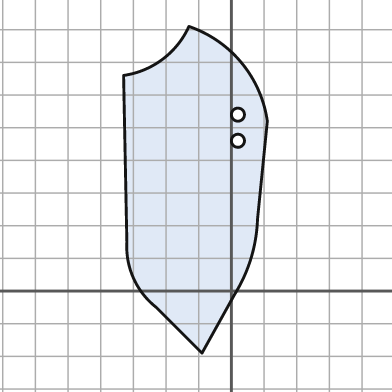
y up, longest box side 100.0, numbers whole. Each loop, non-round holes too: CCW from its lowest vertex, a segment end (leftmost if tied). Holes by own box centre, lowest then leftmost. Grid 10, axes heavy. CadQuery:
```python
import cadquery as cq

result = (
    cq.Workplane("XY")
    .moveTo(-9.0, -19.0)
    .lineTo(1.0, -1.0)
    .threePointArc((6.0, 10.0), (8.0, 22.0))
    .lineTo(11.0, 52.0)
    .threePointArc((3.0, 70.0), (-13.0, 81.0))
    .threePointArc((-21.0, 71.0), (-33.0, 66.0))
    .lineTo(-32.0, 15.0)
    .threePointArc((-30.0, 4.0), (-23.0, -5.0))
    .close()
    .moveTo(2.0, 46.0)
    .circle(2.0)
    .moveTo(2.0, 54.0)
    .circle(2.0)
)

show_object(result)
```